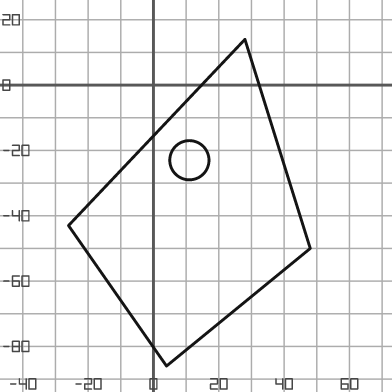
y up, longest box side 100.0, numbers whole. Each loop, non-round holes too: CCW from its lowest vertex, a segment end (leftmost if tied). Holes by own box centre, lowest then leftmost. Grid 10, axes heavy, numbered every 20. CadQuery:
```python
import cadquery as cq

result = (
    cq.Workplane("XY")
    .moveTo(4.0, -86.0)
    .lineTo(48.0, -50.0)
    .lineTo(28.0, 14.0)
    .lineTo(-26.0, -43.0)
    .close()
    .moveTo(11.0, -23.0)
    .circle(6.0)
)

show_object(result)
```